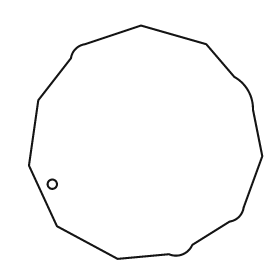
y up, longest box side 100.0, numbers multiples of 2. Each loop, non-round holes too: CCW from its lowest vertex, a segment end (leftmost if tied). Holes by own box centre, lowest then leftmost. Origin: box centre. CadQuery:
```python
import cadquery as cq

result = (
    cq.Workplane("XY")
    .moveTo(-12.0, -50.0)
    .lineTo(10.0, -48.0)
    .threePointArc((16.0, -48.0), (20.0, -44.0))
    .lineTo(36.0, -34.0)
    .threePointArc((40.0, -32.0), (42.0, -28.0))
    .lineTo(50.0, -6.0)
    .lineTo(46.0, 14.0)
    .threePointArc((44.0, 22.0), (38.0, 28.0))
    .lineTo(26.0, 42.0)
    .lineTo(-2.0, 50.0)
    .lineTo(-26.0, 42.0)
    .threePointArc((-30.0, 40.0), (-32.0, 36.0))
    .lineTo(-46.0, 18.0)
    .lineTo(-50.0, -10.0)
    .lineTo(-38.0, -36.0)
    .close()
    .moveTo(-40.0, -18.0)
    .circle(2.0)
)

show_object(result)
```